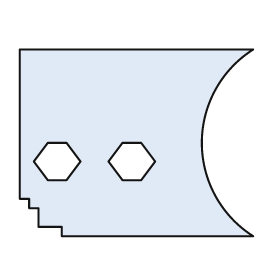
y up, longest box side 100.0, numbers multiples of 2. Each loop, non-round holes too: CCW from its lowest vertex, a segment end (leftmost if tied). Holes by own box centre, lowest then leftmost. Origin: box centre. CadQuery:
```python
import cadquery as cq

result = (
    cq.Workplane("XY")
    .moveTo(-32.0, -40.0)
    .lineTo(50.0, -40.0)
    .threePointArc((28.0, 0.0), (50.0, 40.0))
    .lineTo(-50.0, 40.0)
    .lineTo(-50.0, -24.0)
    .lineTo(-46.0, -24.0)
    .lineTo(-46.0, -28.0)
    .lineTo(-42.0, -28.0)
    .lineTo(-42.0, -36.0)
    .lineTo(-32.0, -36.0)
    .close()
    .moveTo(-38.0, -16.0)
    .lineTo(-30.0, -16.0)
    .lineTo(-24.0, -8.0)
    .lineTo(-30.0, 0.0)
    .lineTo(-38.0, 0.0)
    .lineTo(-44.0, -8.0)
    .close()
    .moveTo(-6.0, -16.0)
    .lineTo(2.0, -16.0)
    .lineTo(8.0, -8.0)
    .lineTo(2.0, 0.0)
    .lineTo(-6.0, 0.0)
    .lineTo(-12.0, -8.0)
    .close()
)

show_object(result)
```